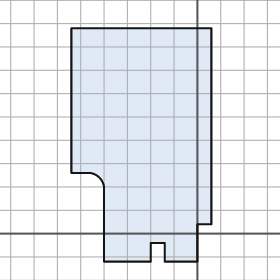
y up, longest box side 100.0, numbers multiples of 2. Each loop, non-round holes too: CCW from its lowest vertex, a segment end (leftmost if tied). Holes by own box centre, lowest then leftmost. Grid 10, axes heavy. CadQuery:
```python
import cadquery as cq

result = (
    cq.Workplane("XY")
    .moveTo(-40.0, -12.0)
    .lineTo(-20.0, -12.0)
    .lineTo(-20.0, -4.0)
    .lineTo(-14.0, -4.0)
    .lineTo(-14.0, -12.0)
    .lineTo(0.0, -12.0)
    .lineTo(0.0, 4.0)
    .lineTo(6.0, 4.0)
    .lineTo(6.0, 88.0)
    .lineTo(-54.0, 88.0)
    .lineTo(-54.0, 26.0)
    .lineTo(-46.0, 26.0)
    .threePointArc((-42.0, 24.0), (-40.0, 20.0))
    .close()
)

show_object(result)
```